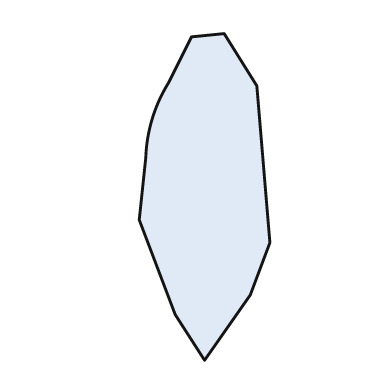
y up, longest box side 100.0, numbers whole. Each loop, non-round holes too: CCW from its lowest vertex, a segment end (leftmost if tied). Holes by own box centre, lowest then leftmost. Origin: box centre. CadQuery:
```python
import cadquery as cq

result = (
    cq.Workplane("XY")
    .moveTo(0.0, -50.0)
    .lineTo(14.0, -30.0)
    .lineTo(20.0, -14.0)
    .lineTo(16.0, 34.0)
    .lineTo(6.0, 50.0)
    .lineTo(-4.0, 49.0)
    .lineTo(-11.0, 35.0)
    .threePointArc((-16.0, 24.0), (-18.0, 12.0))
    .lineTo(-20.0, -7.0)
    .lineTo(-9.0, -36.0)
    .close()
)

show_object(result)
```